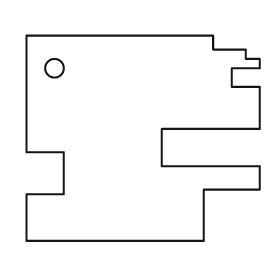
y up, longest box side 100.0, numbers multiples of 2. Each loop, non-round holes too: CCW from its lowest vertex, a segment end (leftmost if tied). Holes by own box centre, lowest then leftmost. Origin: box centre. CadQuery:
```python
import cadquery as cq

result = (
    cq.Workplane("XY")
    .moveTo(-50.0, -44.0)
    .lineTo(26.0, -44.0)
    .lineTo(26.0, -22.0)
    .lineTo(50.0, -22.0)
    .lineTo(50.0, -12.0)
    .lineTo(8.0, -12.0)
    .lineTo(8.0, 4.0)
    .lineTo(50.0, 4.0)
    .lineTo(50.0, 22.0)
    .lineTo(38.0, 22.0)
    .lineTo(38.0, 30.0)
    .lineTo(50.0, 30.0)
    .lineTo(50.0, 34.0)
    .lineTo(44.0, 34.0)
    .lineTo(44.0, 38.0)
    .lineTo(30.0, 38.0)
    .lineTo(30.0, 44.0)
    .lineTo(-50.0, 44.0)
    .lineTo(-50.0, -6.0)
    .lineTo(-34.0, -6.0)
    .lineTo(-34.0, -24.0)
    .lineTo(-50.0, -24.0)
    .close()
    .moveTo(-38.0, 30.0)
    .circle(4.0)
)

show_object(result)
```